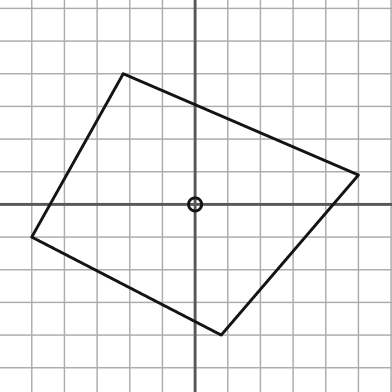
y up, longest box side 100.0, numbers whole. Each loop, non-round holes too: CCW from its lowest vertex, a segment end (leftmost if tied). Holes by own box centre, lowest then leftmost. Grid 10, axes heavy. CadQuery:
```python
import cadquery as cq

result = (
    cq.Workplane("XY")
    .moveTo(8.0, -40.0)
    .lineTo(50.0, 9.0)
    .lineTo(-22.0, 40.0)
    .lineTo(-50.0, -10.0)
    .close()
    .moveTo(0.0, 0.0)
    .circle(2.0)
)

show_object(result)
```